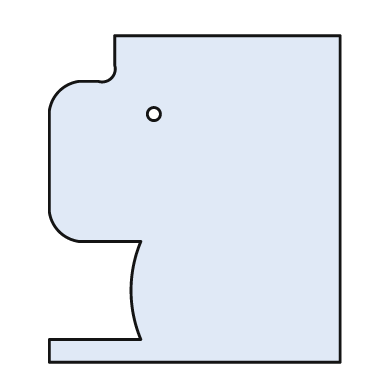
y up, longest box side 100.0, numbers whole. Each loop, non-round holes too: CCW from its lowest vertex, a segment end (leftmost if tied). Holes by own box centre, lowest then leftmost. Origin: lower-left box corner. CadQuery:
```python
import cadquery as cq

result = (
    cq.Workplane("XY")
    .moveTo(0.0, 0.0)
    .lineTo(89.0, 0.0)
    .lineTo(89.0, 100.0)
    .lineTo(20.0, 100.0)
    .lineTo(20.0, 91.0)
    .threePointArc((19.0, 87.0), (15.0, 86.0))
    .lineTo(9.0, 86.0)
    .threePointArc((3.0, 83.0), (0.0, 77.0))
    .lineTo(0.0, 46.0)
    .threePointArc((3.0, 40.0), (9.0, 37.0))
    .lineTo(28.0, 37.0)
    .threePointArc((25.0, 22.0), (28.0, 7.0))
    .lineTo(0.0, 7.0)
    .close()
    .moveTo(32.0, 76.0)
    .circle(2.0)
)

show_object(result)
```